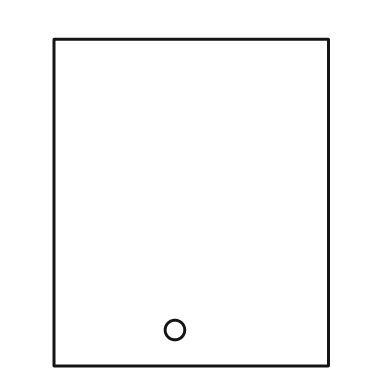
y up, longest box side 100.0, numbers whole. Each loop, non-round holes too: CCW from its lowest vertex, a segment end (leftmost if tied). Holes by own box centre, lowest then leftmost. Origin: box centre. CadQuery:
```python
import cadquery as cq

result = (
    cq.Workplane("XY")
    .moveTo(-42.0, -50.0)
    .lineTo(42.0, -50.0)
    .lineTo(42.0, 50.0)
    .lineTo(-42.0, 50.0)
    .close()
    .moveTo(-5.0, -39.0)
    .circle(3.0)
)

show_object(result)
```